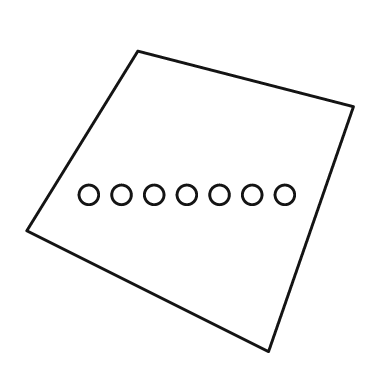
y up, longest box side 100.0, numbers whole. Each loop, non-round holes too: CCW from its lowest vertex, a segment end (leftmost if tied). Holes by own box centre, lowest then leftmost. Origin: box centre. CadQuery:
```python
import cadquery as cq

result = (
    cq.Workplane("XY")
    .moveTo(24.0, -46.0)
    .lineTo(50.0, 29.0)
    .lineTo(-16.0, 46.0)
    .lineTo(-50.0, -9.0)
    .close()
    .moveTo(-31.0, 2.0)
    .circle(3.0)
    .moveTo(-21.0, 2.0)
    .circle(3.0)
    .moveTo(-11.0, 2.0)
    .circle(3.0)
    .moveTo(-1.0, 2.0)
    .circle(3.0)
    .moveTo(9.0, 2.0)
    .circle(3.0)
    .moveTo(19.0, 2.0)
    .circle(3.0)
    .moveTo(29.0, 2.0)
    .circle(3.0)
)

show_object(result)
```